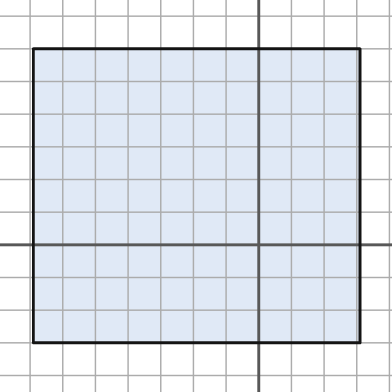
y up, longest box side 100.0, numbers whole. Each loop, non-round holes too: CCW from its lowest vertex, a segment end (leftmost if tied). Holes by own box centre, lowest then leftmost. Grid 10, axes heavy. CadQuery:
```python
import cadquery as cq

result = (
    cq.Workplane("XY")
    .moveTo(-69.0, -30.0)
    .lineTo(31.0, -30.0)
    .lineTo(31.0, 60.0)
    .lineTo(-69.0, 60.0)
    .close()
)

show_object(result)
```